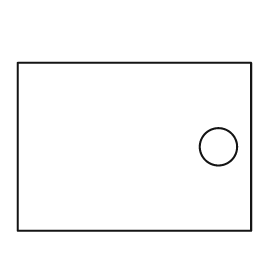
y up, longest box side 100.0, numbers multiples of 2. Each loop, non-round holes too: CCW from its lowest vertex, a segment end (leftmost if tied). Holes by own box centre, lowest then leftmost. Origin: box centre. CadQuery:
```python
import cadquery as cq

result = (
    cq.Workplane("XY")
    .moveTo(-50.0, -36.0)
    .lineTo(50.0, -36.0)
    .lineTo(50.0, 36.0)
    .lineTo(-50.0, 36.0)
    .close()
    .moveTo(36.0, 0.0)
    .circle(8.0)
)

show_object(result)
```